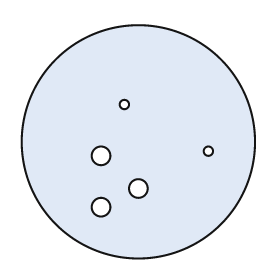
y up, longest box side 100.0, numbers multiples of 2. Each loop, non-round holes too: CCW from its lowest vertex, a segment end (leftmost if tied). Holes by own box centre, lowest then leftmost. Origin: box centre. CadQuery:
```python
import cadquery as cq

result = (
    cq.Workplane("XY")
    .moveTo(0.0, 0.0)
    .circle(50.0)
    .moveTo(-16.0, -28.0)
    .circle(4.0)
    .moveTo(0.0, -20.0)
    .circle(4.0)
    .moveTo(-16.0, -6.0)
    .circle(4.0)
    .moveTo(30.0, -4.0)
    .circle(2.0)
    .moveTo(-6.0, 16.0)
    .circle(2.0)
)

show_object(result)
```